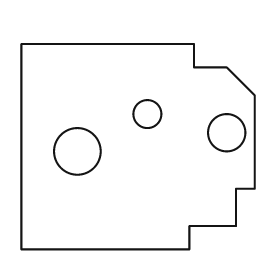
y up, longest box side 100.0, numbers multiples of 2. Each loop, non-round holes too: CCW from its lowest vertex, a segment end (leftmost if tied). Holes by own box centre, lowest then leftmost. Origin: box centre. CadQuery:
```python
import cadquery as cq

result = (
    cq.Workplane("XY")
    .moveTo(-50.0, -44.0)
    .lineTo(22.0, -44.0)
    .lineTo(22.0, -34.0)
    .lineTo(42.0, -34.0)
    .lineTo(42.0, -18.0)
    .lineTo(50.0, -18.0)
    .lineTo(50.0, 22.0)
    .lineTo(38.0, 34.0)
    .lineTo(24.0, 34.0)
    .lineTo(24.0, 44.0)
    .lineTo(-50.0, 44.0)
    .close()
    .moveTo(-26.0, -2.0)
    .circle(10.0)
    .moveTo(38.0, 6.0)
    .circle(8.0)
    .moveTo(4.0, 14.0)
    .circle(6.0)
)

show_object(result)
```